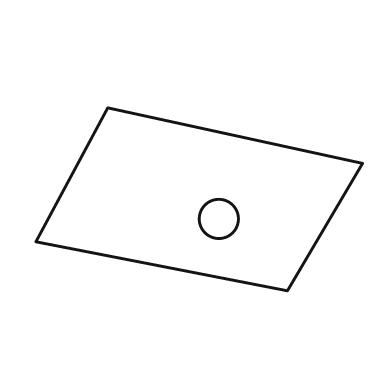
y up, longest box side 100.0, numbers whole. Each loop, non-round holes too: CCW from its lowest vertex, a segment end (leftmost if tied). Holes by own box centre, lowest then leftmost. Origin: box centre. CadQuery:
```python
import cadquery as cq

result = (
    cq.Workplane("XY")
    .moveTo(27.0, -28.0)
    .lineTo(50.0, 11.0)
    .lineTo(-28.0, 28.0)
    .lineTo(-50.0, -13.0)
    .close()
    .moveTo(6.0, -6.0)
    .circle(6.0)
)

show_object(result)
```